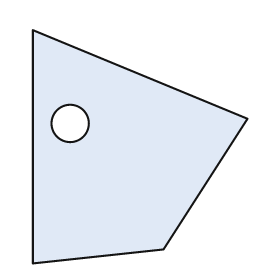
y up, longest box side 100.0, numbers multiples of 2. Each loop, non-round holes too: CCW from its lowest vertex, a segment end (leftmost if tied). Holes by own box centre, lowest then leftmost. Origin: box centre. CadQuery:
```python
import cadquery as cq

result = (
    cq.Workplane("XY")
    .moveTo(-46.0, -50.0)
    .lineTo(10.0, -44.0)
    .lineTo(46.0, 12.0)
    .lineTo(-46.0, 50.0)
    .close()
    .moveTo(-30.0, 10.0)
    .circle(8.0)
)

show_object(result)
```